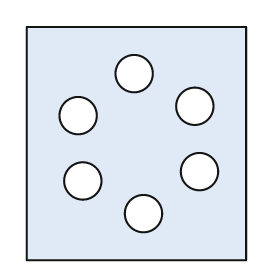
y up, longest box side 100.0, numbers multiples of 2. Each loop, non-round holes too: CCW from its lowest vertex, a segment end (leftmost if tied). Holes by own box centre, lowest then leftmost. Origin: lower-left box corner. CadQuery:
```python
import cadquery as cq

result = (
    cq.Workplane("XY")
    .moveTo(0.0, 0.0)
    .lineTo(94.0, 0.0)
    .lineTo(94.0, 100.0)
    .lineTo(0.0, 100.0)
    .close()
    .moveTo(50.0, 20.0)
    .circle(8.0)
    .moveTo(24.0, 34.0)
    .circle(8.0)
    .moveTo(74.0, 38.0)
    .circle(8.0)
    .moveTo(22.0, 62.0)
    .circle(8.0)
    .moveTo(72.0, 66.0)
    .circle(8.0)
    .moveTo(46.0, 80.0)
    .circle(8.0)
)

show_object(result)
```